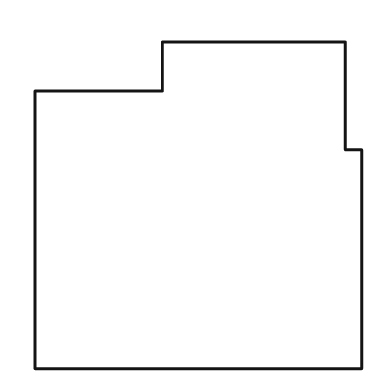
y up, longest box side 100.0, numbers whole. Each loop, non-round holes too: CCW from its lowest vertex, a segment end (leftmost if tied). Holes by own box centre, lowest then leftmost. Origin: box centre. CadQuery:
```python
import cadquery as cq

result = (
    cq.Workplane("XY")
    .moveTo(-50.0, -50.0)
    .lineTo(50.0, -50.0)
    .lineTo(50.0, 17.0)
    .lineTo(45.0, 17.0)
    .lineTo(45.0, 50.0)
    .lineTo(-11.0, 50.0)
    .lineTo(-11.0, 35.0)
    .lineTo(-50.0, 35.0)
    .close()
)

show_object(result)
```